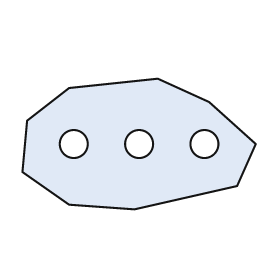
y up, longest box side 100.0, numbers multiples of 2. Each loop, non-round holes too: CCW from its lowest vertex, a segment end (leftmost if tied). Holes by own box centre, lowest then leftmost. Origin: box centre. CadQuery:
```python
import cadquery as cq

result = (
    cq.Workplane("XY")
    .moveTo(-2.0, -28.0)
    .lineTo(42.0, -18.0)
    .lineTo(50.0, 0.0)
    .lineTo(30.0, 18.0)
    .lineTo(8.0, 28.0)
    .lineTo(-30.0, 24.0)
    .lineTo(-48.0, 10.0)
    .lineTo(-50.0, -12.0)
    .lineTo(-30.0, -26.0)
    .close()
    .moveTo(-28.0, 0.0)
    .circle(6.0)
    .moveTo(0.0, 0.0)
    .circle(6.0)
    .moveTo(28.0, 0.0)
    .circle(6.0)
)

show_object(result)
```